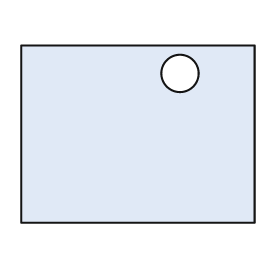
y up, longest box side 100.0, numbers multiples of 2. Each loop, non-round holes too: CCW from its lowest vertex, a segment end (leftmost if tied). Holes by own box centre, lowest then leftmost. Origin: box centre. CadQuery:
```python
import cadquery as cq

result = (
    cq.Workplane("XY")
    .moveTo(-50.0, -38.0)
    .lineTo(50.0, -38.0)
    .lineTo(50.0, 38.0)
    .lineTo(-50.0, 38.0)
    .close()
    .moveTo(18.0, 26.0)
    .circle(8.0)
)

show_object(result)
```